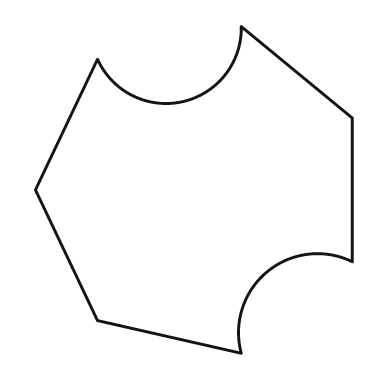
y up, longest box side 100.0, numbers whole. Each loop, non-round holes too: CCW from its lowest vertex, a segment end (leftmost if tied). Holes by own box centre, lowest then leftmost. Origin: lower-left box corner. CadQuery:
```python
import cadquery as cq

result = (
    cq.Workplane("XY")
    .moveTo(63.0, 0.0)
    .threePointArc((71.0, 25.0), (97.0, 28.0))
    .lineTo(97.0, 72.0)
    .lineTo(63.0, 100.0)
    .threePointArc((45.0, 77.0), (19.0, 90.0))
    .lineTo(0.0, 50.0)
    .lineTo(19.0, 10.0)
    .close()
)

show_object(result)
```